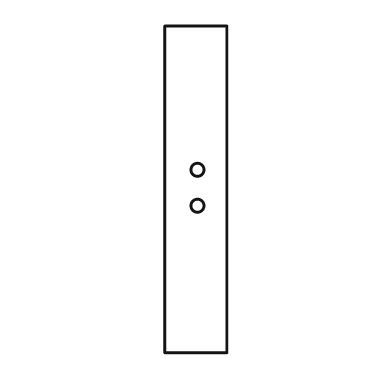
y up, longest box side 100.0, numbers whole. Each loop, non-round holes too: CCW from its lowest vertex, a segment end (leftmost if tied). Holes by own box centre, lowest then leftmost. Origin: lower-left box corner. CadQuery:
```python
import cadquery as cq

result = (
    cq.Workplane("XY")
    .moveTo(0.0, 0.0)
    .lineTo(19.0, 0.0)
    .lineTo(19.0, 100.0)
    .lineTo(0.0, 100.0)
    .close()
    .moveTo(10.0, 45.0)
    .circle(2.0)
    .moveTo(10.0, 56.0)
    .circle(2.0)
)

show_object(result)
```